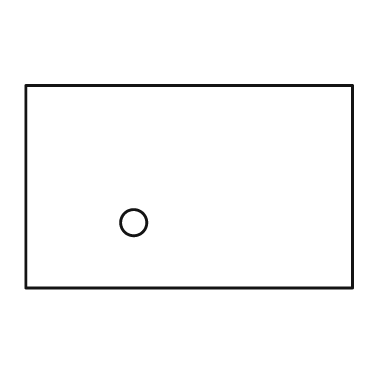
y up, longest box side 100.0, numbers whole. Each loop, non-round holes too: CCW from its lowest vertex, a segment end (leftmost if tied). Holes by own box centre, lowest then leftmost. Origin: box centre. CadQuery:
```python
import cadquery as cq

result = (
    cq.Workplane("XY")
    .moveTo(-50.0, -31.0)
    .lineTo(50.0, -31.0)
    .lineTo(50.0, 31.0)
    .lineTo(-50.0, 31.0)
    .close()
    .moveTo(-17.0, -11.0)
    .circle(4.0)
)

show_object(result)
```